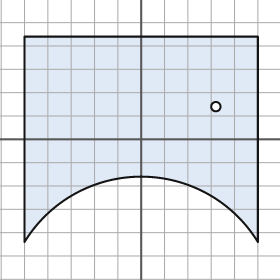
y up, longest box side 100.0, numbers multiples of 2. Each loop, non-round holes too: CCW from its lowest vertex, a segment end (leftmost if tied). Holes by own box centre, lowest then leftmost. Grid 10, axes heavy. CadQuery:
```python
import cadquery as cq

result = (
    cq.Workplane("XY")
    .moveTo(-50.0, -44.0)
    .threePointArc((0.0, -16.0), (50.0, -44.0))
    .lineTo(50.0, 44.0)
    .lineTo(-50.0, 44.0)
    .close()
    .moveTo(32.0, 14.0)
    .circle(2.0)
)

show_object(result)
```